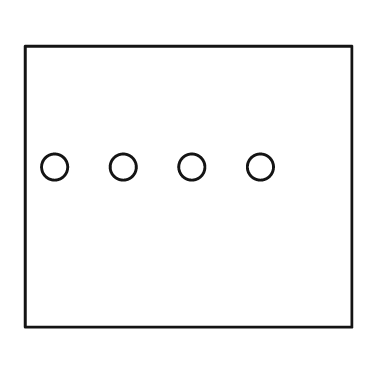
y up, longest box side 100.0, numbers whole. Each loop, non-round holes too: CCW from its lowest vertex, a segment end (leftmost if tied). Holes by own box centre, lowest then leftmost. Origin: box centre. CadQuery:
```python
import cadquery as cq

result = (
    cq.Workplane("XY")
    .moveTo(-50.0, -43.0)
    .lineTo(50.0, -43.0)
    .lineTo(50.0, 43.0)
    .lineTo(-50.0, 43.0)
    .close()
    .moveTo(-41.0, 6.0)
    .circle(4.0)
    .moveTo(-20.0, 6.0)
    .circle(4.0)
    .moveTo(1.0, 6.0)
    .circle(4.0)
    .moveTo(22.0, 6.0)
    .circle(4.0)
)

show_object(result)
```